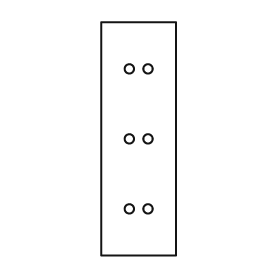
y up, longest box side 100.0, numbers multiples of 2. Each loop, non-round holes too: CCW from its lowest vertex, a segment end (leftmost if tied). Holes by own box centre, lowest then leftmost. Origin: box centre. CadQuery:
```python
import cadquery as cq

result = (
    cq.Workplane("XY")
    .moveTo(-16.0, -50.0)
    .lineTo(16.0, -50.0)
    .lineTo(16.0, 50.0)
    .lineTo(-16.0, 50.0)
    .close()
    .moveTo(-4.0, -30.0)
    .circle(2.0)
    .moveTo(4.0, -30.0)
    .circle(2.0)
    .moveTo(-4.0, 0.0)
    .circle(2.0)
    .moveTo(4.0, 0.0)
    .circle(2.0)
    .moveTo(-4.0, 30.0)
    .circle(2.0)
    .moveTo(4.0, 30.0)
    .circle(2.0)
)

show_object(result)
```